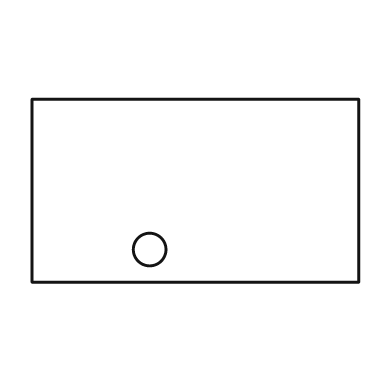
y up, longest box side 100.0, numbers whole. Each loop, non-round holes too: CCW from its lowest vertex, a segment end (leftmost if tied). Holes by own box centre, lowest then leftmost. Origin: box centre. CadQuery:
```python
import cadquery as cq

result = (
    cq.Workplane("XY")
    .moveTo(-50.0, -28.0)
    .lineTo(50.0, -28.0)
    .lineTo(50.0, 28.0)
    .lineTo(-50.0, 28.0)
    .close()
    .moveTo(-14.0, -18.0)
    .circle(5.0)
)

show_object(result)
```